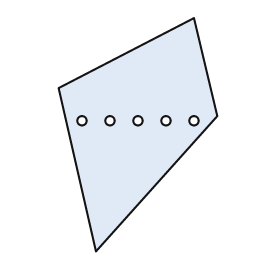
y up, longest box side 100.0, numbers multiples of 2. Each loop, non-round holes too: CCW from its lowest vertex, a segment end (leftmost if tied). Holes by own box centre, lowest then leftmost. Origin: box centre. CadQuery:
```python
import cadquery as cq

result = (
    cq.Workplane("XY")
    .moveTo(-18.0, -50.0)
    .lineTo(34.0, 8.0)
    .lineTo(24.0, 50.0)
    .lineTo(-34.0, 20.0)
    .close()
    .moveTo(-24.0, 6.0)
    .circle(2.0)
    .moveTo(-12.0, 6.0)
    .circle(2.0)
    .moveTo(0.0, 6.0)
    .circle(2.0)
    .moveTo(12.0, 6.0)
    .circle(2.0)
    .moveTo(24.0, 6.0)
    .circle(2.0)
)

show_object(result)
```